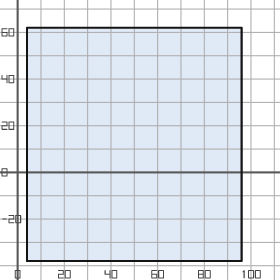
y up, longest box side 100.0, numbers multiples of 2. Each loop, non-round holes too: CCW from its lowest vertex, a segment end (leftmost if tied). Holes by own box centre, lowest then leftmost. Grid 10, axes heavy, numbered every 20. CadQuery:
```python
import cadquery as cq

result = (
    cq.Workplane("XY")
    .moveTo(4.0, -38.0)
    .lineTo(96.0, -38.0)
    .lineTo(96.0, 62.0)
    .lineTo(4.0, 62.0)
    .close()
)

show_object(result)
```